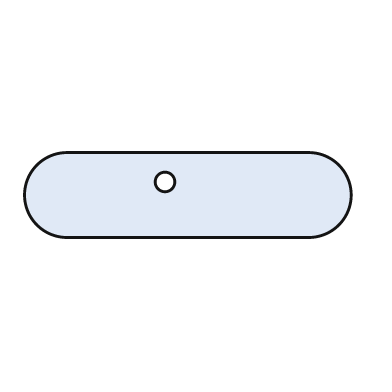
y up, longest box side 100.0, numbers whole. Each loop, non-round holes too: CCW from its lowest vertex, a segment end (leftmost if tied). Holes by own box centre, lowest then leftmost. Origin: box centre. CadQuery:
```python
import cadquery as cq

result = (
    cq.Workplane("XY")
    .moveTo(-37.0, -13.0)
    .lineTo(37.0, -13.0)
    .threePointArc((50.0, 0.0), (37.0, 13.0))
    .lineTo(-37.0, 13.0)
    .threePointArc((-50.0, 0.0), (-37.0, -13.0))
    .close()
    .moveTo(-7.0, 4.0)
    .circle(3.0)
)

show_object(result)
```